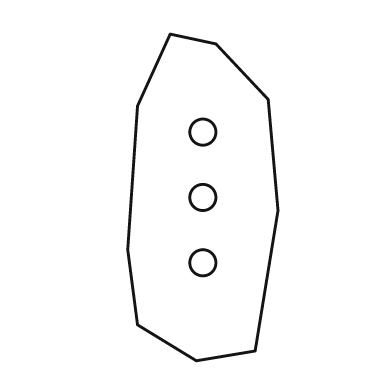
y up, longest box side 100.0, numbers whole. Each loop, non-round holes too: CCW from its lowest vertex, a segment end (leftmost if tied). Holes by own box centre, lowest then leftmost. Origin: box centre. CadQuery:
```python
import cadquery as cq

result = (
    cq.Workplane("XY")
    .moveTo(-2.0, -50.0)
    .lineTo(16.0, -47.0)
    .lineTo(23.0, -4.0)
    .lineTo(20.0, 30.0)
    .lineTo(4.0, 47.0)
    .lineTo(-10.0, 50.0)
    .lineTo(-20.0, 28.0)
    .lineTo(-23.0, -16.0)
    .lineTo(-20.0, -39.0)
    .close()
    .moveTo(0.0, -20.0)
    .circle(4.0)
    .moveTo(0.0, 0.0)
    .circle(4.0)
    .moveTo(0.0, 20.0)
    .circle(4.0)
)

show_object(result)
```